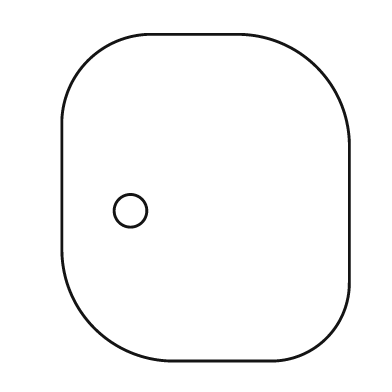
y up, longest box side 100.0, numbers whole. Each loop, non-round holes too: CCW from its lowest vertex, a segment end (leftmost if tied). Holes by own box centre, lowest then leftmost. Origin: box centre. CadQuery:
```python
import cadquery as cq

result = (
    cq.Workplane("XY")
    .moveTo(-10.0, -50.0)
    .lineTo(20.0, -50.0)
    .threePointArc((37.0, -43.0), (44.0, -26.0))
    .lineTo(44.0, 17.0)
    .threePointArc((34.0, 40.0), (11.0, 50.0))
    .lineTo(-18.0, 50.0)
    .threePointArc((-36.0, 42.0), (-44.0, 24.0))
    .lineTo(-44.0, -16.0)
    .threePointArc((-34.0, -40.0), (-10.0, -50.0))
    .close()
    .moveTo(-23.0, -4.0)
    .circle(5.0)
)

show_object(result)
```